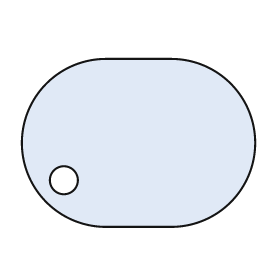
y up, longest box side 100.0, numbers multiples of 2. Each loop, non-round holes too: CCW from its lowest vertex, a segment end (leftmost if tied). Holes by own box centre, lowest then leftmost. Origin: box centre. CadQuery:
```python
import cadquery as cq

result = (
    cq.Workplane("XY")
    .moveTo(-14.0, -36.0)
    .lineTo(14.0, -36.0)
    .threePointArc((50.0, 0.0), (14.0, 36.0))
    .lineTo(-14.0, 36.0)
    .threePointArc((-50.0, 0.0), (-14.0, -36.0))
    .close()
    .moveTo(-32.0, -16.0)
    .circle(6.0)
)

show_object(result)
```